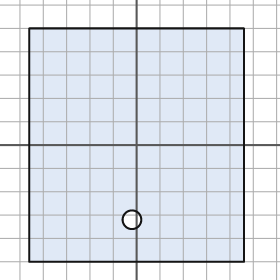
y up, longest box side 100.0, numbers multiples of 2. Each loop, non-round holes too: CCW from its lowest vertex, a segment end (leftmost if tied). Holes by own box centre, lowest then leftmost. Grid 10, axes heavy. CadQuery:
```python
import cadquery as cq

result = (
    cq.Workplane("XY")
    .moveTo(-46.0, -50.0)
    .lineTo(46.0, -50.0)
    .lineTo(46.0, 50.0)
    .lineTo(-46.0, 50.0)
    .close()
    .moveTo(-2.0, -32.0)
    .circle(4.0)
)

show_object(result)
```